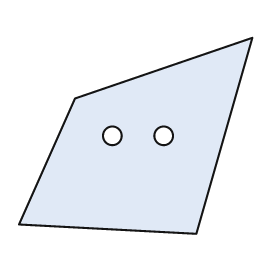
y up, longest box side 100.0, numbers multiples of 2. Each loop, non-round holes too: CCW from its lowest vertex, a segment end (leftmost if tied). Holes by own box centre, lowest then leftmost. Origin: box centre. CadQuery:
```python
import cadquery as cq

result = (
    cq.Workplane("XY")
    .moveTo(26.0, -42.0)
    .lineTo(50.0, 42.0)
    .lineTo(-26.0, 16.0)
    .lineTo(-50.0, -38.0)
    .close()
    .moveTo(-10.0, 0.0)
    .circle(4.0)
    .moveTo(12.0, 0.0)
    .circle(4.0)
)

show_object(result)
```